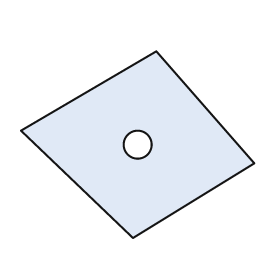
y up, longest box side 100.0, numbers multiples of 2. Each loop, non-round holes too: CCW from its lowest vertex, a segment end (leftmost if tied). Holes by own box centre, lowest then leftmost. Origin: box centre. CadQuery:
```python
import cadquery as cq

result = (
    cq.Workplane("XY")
    .moveTo(-2.0, -40.0)
    .lineTo(50.0, -8.0)
    .lineTo(8.0, 40.0)
    .lineTo(-50.0, 6.0)
    .close()
    .moveTo(0.0, 0.0)
    .circle(6.0)
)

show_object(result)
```